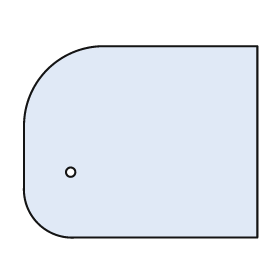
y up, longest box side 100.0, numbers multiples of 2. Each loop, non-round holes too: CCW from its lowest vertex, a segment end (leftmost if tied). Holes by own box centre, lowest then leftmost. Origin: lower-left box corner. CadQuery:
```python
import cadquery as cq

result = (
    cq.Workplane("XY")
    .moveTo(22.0, 0.0)
    .lineTo(100.0, 0.0)
    .lineTo(100.0, 82.0)
    .lineTo(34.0, 82.0)
    .threePointArc((10.0, 72.0), (0.0, 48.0))
    .lineTo(0.0, 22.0)
    .threePointArc((6.0, 6.0), (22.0, 0.0))
    .close()
    .moveTo(20.0, 28.0)
    .circle(2.0)
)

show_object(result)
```